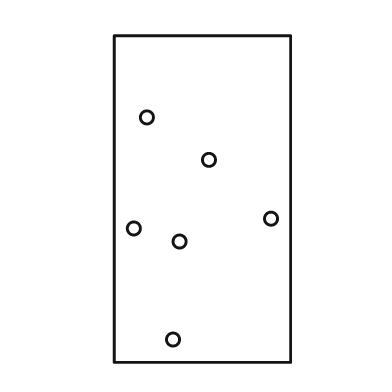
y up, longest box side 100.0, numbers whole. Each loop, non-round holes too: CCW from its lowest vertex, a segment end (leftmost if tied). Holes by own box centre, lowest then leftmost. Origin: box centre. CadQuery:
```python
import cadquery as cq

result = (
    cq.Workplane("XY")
    .moveTo(-27.0, -50.0)
    .lineTo(27.0, -50.0)
    .lineTo(27.0, 50.0)
    .lineTo(-27.0, 50.0)
    .close()
    .moveTo(-9.0, -43.0)
    .circle(2.0)
    .moveTo(-7.0, -13.0)
    .circle(2.0)
    .moveTo(-21.0, -9.0)
    .circle(2.0)
    .moveTo(21.0, -6.0)
    .circle(2.0)
    .moveTo(2.0, 12.0)
    .circle(2.0)
    .moveTo(-17.0, 25.0)
    .circle(2.0)
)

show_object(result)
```